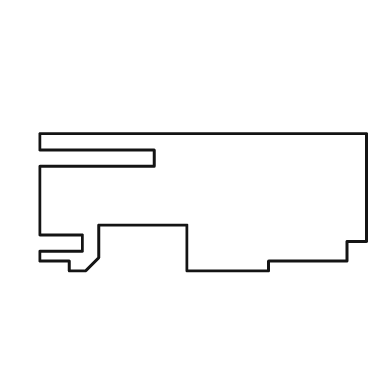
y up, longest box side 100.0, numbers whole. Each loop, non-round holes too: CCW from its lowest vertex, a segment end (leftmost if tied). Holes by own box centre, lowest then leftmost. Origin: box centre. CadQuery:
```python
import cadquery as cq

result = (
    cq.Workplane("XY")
    .moveTo(-41.0, -21.0)
    .lineTo(-36.0, -21.0)
    .lineTo(-32.0, -17.0)
    .lineTo(-32.0, -7.0)
    .lineTo(-5.0, -7.0)
    .lineTo(-5.0, -21.0)
    .lineTo(20.0, -21.0)
    .lineTo(20.0, -18.0)
    .lineTo(44.0, -18.0)
    .lineTo(44.0, -12.0)
    .lineTo(50.0, -12.0)
    .lineTo(50.0, 21.0)
    .lineTo(-50.0, 21.0)
    .lineTo(-50.0, 16.0)
    .lineTo(-15.0, 16.0)
    .lineTo(-15.0, 11.0)
    .lineTo(-50.0, 11.0)
    .lineTo(-50.0, -10.0)
    .lineTo(-37.0, -10.0)
    .lineTo(-37.0, -15.0)
    .lineTo(-50.0, -15.0)
    .lineTo(-50.0, -18.0)
    .lineTo(-41.0, -18.0)
    .close()
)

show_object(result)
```